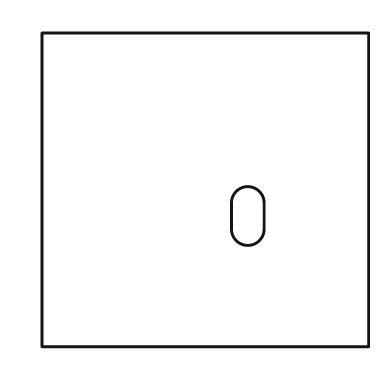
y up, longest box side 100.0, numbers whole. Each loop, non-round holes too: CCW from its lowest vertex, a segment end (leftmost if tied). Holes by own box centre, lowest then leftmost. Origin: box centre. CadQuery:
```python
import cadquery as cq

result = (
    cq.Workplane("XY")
    .moveTo(-50.0, -48.0)
    .lineTo(50.0, -48.0)
    .lineTo(50.0, 48.0)
    .lineTo(-50.0, 48.0)
    .close()
    .moveTo(8.0, -12.0)
    .threePointArc((13.0, -17.0), (18.0, -12.0))
    .lineTo(18.0, -4.0)
    .threePointArc((13.0, 1.0), (8.0, -4.0))
    .close()
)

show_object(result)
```